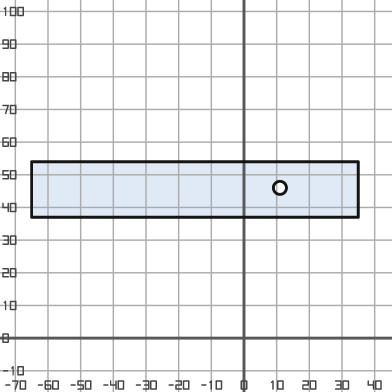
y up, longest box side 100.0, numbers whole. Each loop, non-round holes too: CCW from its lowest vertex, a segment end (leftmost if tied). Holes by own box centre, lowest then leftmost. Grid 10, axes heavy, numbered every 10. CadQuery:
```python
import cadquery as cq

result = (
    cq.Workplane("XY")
    .moveTo(-65.0, 37.0)
    .lineTo(35.0, 37.0)
    .lineTo(35.0, 54.0)
    .lineTo(-65.0, 54.0)
    .close()
    .moveTo(11.0, 46.0)
    .circle(2.0)
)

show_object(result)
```